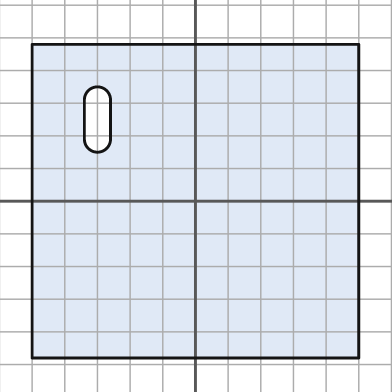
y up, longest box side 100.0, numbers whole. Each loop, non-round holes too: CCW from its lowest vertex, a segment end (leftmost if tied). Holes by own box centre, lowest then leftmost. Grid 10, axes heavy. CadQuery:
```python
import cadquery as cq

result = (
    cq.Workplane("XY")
    .moveTo(-50.0, -48.0)
    .lineTo(50.0, -48.0)
    .lineTo(50.0, 48.0)
    .lineTo(-50.0, 48.0)
    .close()
    .moveTo(-34.0, 19.0)
    .threePointArc((-30.0, 15.0), (-26.0, 19.0))
    .lineTo(-26.0, 31.0)
    .threePointArc((-30.0, 35.0), (-34.0, 31.0))
    .close()
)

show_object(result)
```